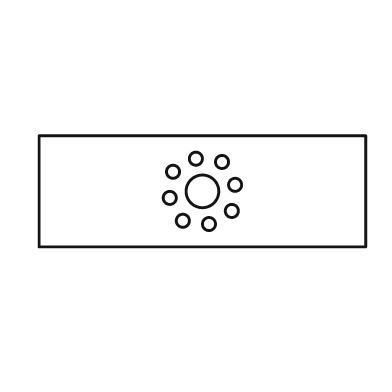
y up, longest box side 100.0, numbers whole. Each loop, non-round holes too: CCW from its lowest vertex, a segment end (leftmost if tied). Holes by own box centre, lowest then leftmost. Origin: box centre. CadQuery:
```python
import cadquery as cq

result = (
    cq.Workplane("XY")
    .moveTo(-50.0, -17.0)
    .lineTo(50.0, -17.0)
    .lineTo(50.0, 17.0)
    .lineTo(-50.0, 17.0)
    .close()
    .moveTo(2.0, -10.0)
    .circle(2.0)
    .moveTo(-6.0, -9.0)
    .circle(2.0)
    .moveTo(9.0, -6.0)
    .circle(2.0)
    .moveTo(-10.0, -2.0)
    .circle(2.0)
    .moveTo(0.0, 0.0)
    .circle(5.0)
    .moveTo(10.0, 2.0)
    .circle(2.0)
    .moveTo(-9.0, 6.0)
    .circle(2.0)
    .moveTo(6.0, 9.0)
    .circle(2.0)
    .moveTo(-2.0, 10.0)
    .circle(2.0)
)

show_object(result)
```